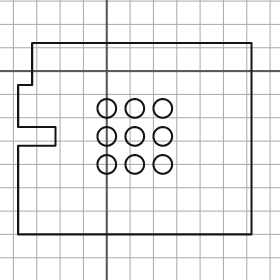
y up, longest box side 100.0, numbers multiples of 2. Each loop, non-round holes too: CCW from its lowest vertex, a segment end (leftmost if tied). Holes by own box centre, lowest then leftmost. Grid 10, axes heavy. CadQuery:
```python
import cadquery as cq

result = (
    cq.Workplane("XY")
    .moveTo(-38.0, -70.0)
    .lineTo(62.0, -70.0)
    .lineTo(62.0, 12.0)
    .lineTo(-32.0, 12.0)
    .lineTo(-32.0, -6.0)
    .lineTo(-38.0, -6.0)
    .lineTo(-38.0, -24.0)
    .lineTo(-22.0, -24.0)
    .lineTo(-22.0, -32.0)
    .lineTo(-38.0, -32.0)
    .close()
    .moveTo(0.0, -40.0)
    .circle(4.0)
    .moveTo(12.0, -40.0)
    .circle(4.0)
    .moveTo(24.0, -40.0)
    .circle(4.0)
    .moveTo(0.0, -28.0)
    .circle(4.0)
    .moveTo(12.0, -28.0)
    .circle(4.0)
    .moveTo(24.0, -28.0)
    .circle(4.0)
    .moveTo(0.0, -16.0)
    .circle(4.0)
    .moveTo(12.0, -16.0)
    .circle(4.0)
    .moveTo(24.0, -16.0)
    .circle(4.0)
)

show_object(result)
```